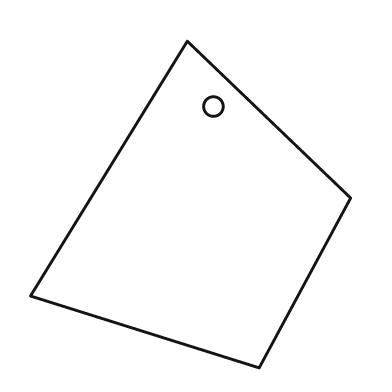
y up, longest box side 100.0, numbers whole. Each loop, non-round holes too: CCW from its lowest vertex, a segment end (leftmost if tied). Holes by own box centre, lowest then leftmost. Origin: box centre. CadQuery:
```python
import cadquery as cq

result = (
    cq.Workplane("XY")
    .moveTo(21.0, -50.0)
    .lineTo(49.0, 2.0)
    .lineTo(-1.0, 50.0)
    .lineTo(-49.0, -28.0)
    .close()
    .moveTo(7.0, 30.0)
    .circle(3.0)
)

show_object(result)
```